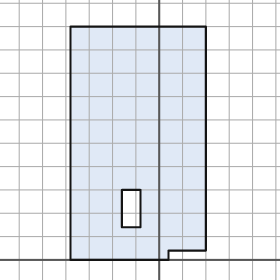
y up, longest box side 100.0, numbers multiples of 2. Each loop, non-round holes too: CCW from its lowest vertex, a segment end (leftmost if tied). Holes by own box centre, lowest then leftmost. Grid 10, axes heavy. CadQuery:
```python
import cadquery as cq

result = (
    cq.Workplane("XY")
    .moveTo(-38.0, 0.0)
    .lineTo(4.0, 0.0)
    .lineTo(4.0, 4.0)
    .lineTo(20.0, 4.0)
    .lineTo(20.0, 100.0)
    .lineTo(-38.0, 100.0)
    .close()
    .moveTo(-16.0, 14.0)
    .lineTo(-8.0, 14.0)
    .lineTo(-8.0, 30.0)
    .lineTo(-16.0, 30.0)
    .close()
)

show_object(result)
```